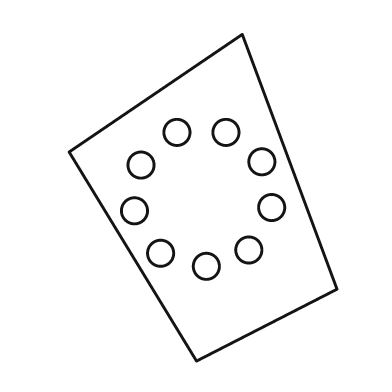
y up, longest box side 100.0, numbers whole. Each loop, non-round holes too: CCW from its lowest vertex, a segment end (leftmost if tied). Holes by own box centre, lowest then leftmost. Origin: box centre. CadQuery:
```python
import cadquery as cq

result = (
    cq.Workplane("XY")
    .moveTo(-2.0, -50.0)
    .lineTo(41.0, -28.0)
    .lineTo(12.0, 50.0)
    .lineTo(-41.0, 14.0)
    .close()
    .moveTo(1.0, -21.0)
    .circle(4.0)
    .moveTo(-13.0, -17.0)
    .circle(4.0)
    .moveTo(14.0, -16.0)
    .circle(4.0)
    .moveTo(-21.0, -4.0)
    .circle(4.0)
    .moveTo(21.0, -3.0)
    .circle(4.0)
    .moveTo(-19.0, 10.0)
    .circle(4.0)
    .moveTo(18.0, 11.0)
    .circle(4.0)
    .moveTo(-8.0, 20.0)
    .circle(4.0)
    .moveTo(7.0, 20.0)
    .circle(4.0)
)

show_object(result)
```